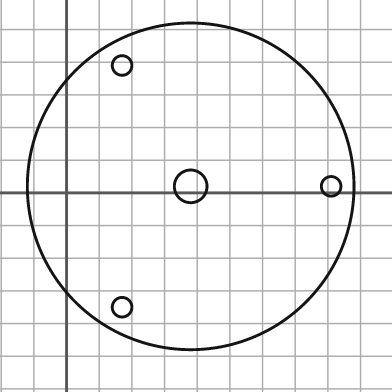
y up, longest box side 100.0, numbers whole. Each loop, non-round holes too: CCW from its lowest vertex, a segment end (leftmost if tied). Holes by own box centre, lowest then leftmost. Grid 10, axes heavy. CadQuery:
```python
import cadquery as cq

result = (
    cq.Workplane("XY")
    .moveTo(38.0, 2.0)
    .circle(50.0)
    .moveTo(17.0, -35.0)
    .circle(3.0)
    .moveTo(38.0, 2.0)
    .circle(5.0)
    .moveTo(81.0, 2.0)
    .circle(3.0)
    .moveTo(17.0, 39.0)
    .circle(3.0)
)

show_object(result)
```